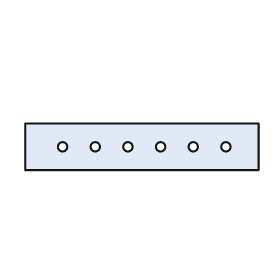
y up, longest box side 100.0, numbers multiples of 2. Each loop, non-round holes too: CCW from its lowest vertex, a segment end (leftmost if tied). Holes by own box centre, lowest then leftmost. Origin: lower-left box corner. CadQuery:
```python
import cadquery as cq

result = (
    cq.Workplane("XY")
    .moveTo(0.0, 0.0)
    .lineTo(100.0, 0.0)
    .lineTo(100.0, 20.0)
    .lineTo(0.0, 20.0)
    .close()
    .moveTo(16.0, 10.0)
    .circle(2.0)
    .moveTo(30.0, 10.0)
    .circle(2.0)
    .moveTo(44.0, 10.0)
    .circle(2.0)
    .moveTo(58.0, 10.0)
    .circle(2.0)
    .moveTo(72.0, 10.0)
    .circle(2.0)
    .moveTo(86.0, 10.0)
    .circle(2.0)
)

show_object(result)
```